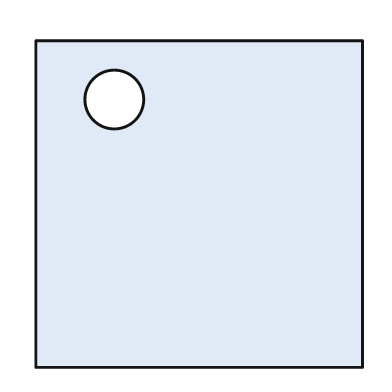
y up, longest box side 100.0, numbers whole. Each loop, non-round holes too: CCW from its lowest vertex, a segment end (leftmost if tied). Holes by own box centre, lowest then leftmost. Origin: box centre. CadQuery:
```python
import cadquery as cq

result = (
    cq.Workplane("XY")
    .moveTo(-50.0, -50.0)
    .lineTo(50.0, -50.0)
    .lineTo(50.0, 50.0)
    .lineTo(-50.0, 50.0)
    .close()
    .moveTo(-26.0, 32.0)
    .circle(9.0)
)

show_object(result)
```